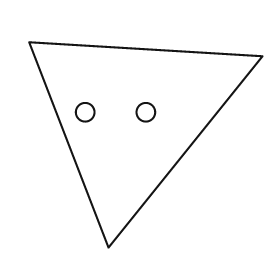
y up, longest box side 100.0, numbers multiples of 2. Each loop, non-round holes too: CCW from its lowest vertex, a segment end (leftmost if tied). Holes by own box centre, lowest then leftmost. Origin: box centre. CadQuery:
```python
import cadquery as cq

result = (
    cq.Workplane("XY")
    .moveTo(-16.0, -44.0)
    .lineTo(50.0, 38.0)
    .lineTo(-50.0, 44.0)
    .close()
    .moveTo(-26.0, 14.0)
    .circle(4.0)
    .moveTo(0.0, 14.0)
    .circle(4.0)
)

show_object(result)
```